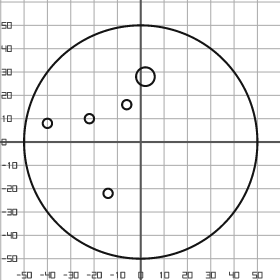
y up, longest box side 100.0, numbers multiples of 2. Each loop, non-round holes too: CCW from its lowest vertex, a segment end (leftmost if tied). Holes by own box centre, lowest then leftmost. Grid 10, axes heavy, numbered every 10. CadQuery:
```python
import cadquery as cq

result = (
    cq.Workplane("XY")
    .moveTo(0.0, 0.0)
    .circle(50.0)
    .moveTo(-14.0, -22.0)
    .circle(2.0)
    .moveTo(-40.0, 8.0)
    .circle(2.0)
    .moveTo(-22.0, 10.0)
    .circle(2.0)
    .moveTo(-6.0, 16.0)
    .circle(2.0)
    .moveTo(2.0, 28.0)
    .circle(4.0)
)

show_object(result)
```